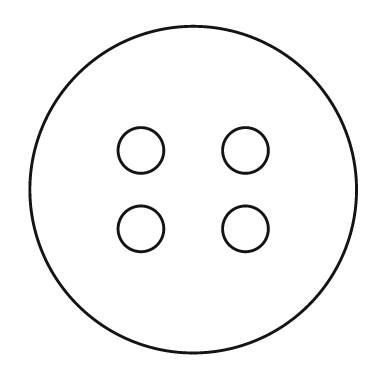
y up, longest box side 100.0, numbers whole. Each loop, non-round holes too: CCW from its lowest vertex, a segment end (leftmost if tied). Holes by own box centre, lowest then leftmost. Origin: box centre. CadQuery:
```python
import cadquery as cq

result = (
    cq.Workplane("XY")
    .moveTo(0.0, 0.0)
    .circle(50.0)
    .moveTo(-16.0, -12.0)
    .circle(7.0)
    .moveTo(16.0, -12.0)
    .circle(7.0)
    .moveTo(-16.0, 12.0)
    .circle(7.0)
    .moveTo(16.0, 12.0)
    .circle(7.0)
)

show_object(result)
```